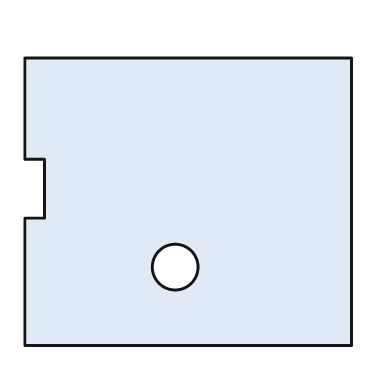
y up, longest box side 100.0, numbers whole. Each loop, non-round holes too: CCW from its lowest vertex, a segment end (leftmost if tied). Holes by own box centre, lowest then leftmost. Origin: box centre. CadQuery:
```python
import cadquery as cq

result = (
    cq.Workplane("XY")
    .moveTo(-50.0, -44.0)
    .lineTo(50.0, -44.0)
    .lineTo(50.0, 44.0)
    .lineTo(-50.0, 44.0)
    .lineTo(-50.0, 13.0)
    .lineTo(-44.0, 13.0)
    .lineTo(-44.0, -5.0)
    .lineTo(-50.0, -5.0)
    .close()
    .moveTo(-4.0, -20.0)
    .circle(7.0)
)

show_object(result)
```